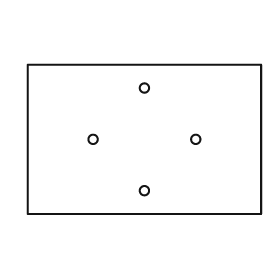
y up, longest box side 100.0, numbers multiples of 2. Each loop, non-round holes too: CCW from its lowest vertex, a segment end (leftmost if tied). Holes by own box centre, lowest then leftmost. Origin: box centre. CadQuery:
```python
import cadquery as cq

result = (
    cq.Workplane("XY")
    .moveTo(-50.0, -32.0)
    .lineTo(50.0, -32.0)
    .lineTo(50.0, 32.0)
    .lineTo(-50.0, 32.0)
    .close()
    .moveTo(0.0, -22.0)
    .circle(2.0)
    .moveTo(-22.0, 0.0)
    .circle(2.0)
    .moveTo(22.0, 0.0)
    .circle(2.0)
    .moveTo(0.0, 22.0)
    .circle(2.0)
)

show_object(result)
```